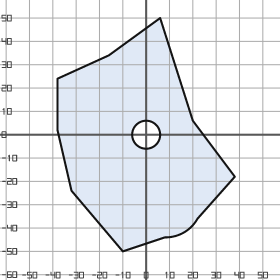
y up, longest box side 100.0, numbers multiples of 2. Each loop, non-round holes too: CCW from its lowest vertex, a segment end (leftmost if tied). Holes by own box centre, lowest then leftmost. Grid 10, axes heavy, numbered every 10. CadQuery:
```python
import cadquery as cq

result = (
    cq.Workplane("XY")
    .moveTo(-10.0, -50.0)
    .lineTo(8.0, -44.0)
    .threePointArc((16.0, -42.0), (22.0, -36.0))
    .lineTo(38.0, -18.0)
    .lineTo(20.0, 6.0)
    .lineTo(6.0, 50.0)
    .lineTo(-16.0, 34.0)
    .lineTo(-38.0, 24.0)
    .lineTo(-38.0, 2.0)
    .lineTo(-32.0, -24.0)
    .close()
    .moveTo(0.0, 0.0)
    .circle(6.0)
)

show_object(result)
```